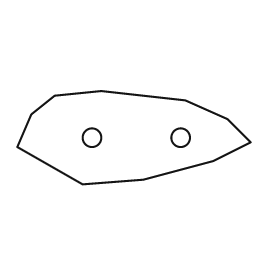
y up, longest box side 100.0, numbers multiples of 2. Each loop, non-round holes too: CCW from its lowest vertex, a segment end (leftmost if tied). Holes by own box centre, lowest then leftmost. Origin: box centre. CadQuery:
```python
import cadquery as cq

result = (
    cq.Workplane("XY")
    .moveTo(-22.0, -20.0)
    .lineTo(4.0, -18.0)
    .lineTo(34.0, -10.0)
    .lineTo(50.0, -2.0)
    .lineTo(40.0, 8.0)
    .lineTo(22.0, 16.0)
    .lineTo(-14.0, 20.0)
    .lineTo(-34.0, 18.0)
    .lineTo(-44.0, 10.0)
    .lineTo(-50.0, -4.0)
    .close()
    .moveTo(-18.0, 0.0)
    .circle(4.0)
    .moveTo(20.0, 0.0)
    .circle(4.0)
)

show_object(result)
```